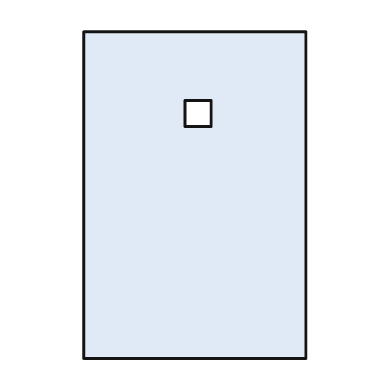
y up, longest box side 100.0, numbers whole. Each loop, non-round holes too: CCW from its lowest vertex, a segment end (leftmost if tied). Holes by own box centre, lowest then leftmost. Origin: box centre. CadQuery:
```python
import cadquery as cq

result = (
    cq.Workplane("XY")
    .moveTo(-34.0, -50.0)
    .lineTo(34.0, -50.0)
    .lineTo(34.0, 50.0)
    .lineTo(-34.0, 50.0)
    .close()
    .moveTo(-3.0, 21.0)
    .lineTo(5.0, 21.0)
    .lineTo(5.0, 29.0)
    .lineTo(-3.0, 29.0)
    .close()
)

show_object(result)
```